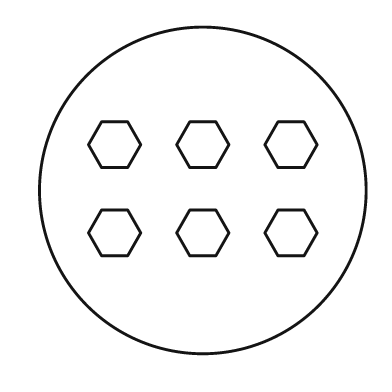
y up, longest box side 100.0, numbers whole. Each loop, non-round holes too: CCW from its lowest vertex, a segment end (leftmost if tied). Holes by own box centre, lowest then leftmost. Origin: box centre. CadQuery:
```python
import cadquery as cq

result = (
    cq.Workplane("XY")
    .moveTo(0.0, 0.0)
    .circle(50.0)
    .moveTo(-31.0, -20.0)
    .lineTo(-23.0, -20.0)
    .lineTo(-19.0, -13.0)
    .lineTo(-23.0, -6.0)
    .lineTo(-31.0, -6.0)
    .lineTo(-35.0, -13.0)
    .close()
    .moveTo(-4.0, -20.0)
    .lineTo(4.0, -20.0)
    .lineTo(8.0, -13.0)
    .lineTo(4.0, -6.0)
    .lineTo(-4.0, -6.0)
    .lineTo(-8.0, -13.0)
    .close()
    .moveTo(23.0, -20.0)
    .lineTo(31.0, -20.0)
    .lineTo(35.0, -13.0)
    .lineTo(31.0, -6.0)
    .lineTo(23.0, -6.0)
    .lineTo(19.0, -13.0)
    .close()
    .moveTo(-31.0, 7.0)
    .lineTo(-23.0, 7.0)
    .lineTo(-19.0, 14.0)
    .lineTo(-23.0, 21.0)
    .lineTo(-31.0, 21.0)
    .lineTo(-35.0, 14.0)
    .close()
    .moveTo(-4.0, 7.0)
    .lineTo(4.0, 7.0)
    .lineTo(8.0, 14.0)
    .lineTo(4.0, 21.0)
    .lineTo(-4.0, 21.0)
    .lineTo(-8.0, 14.0)
    .close()
    .moveTo(23.0, 7.0)
    .lineTo(31.0, 7.0)
    .lineTo(35.0, 14.0)
    .lineTo(31.0, 21.0)
    .lineTo(23.0, 21.0)
    .lineTo(19.0, 14.0)
    .close()
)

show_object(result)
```